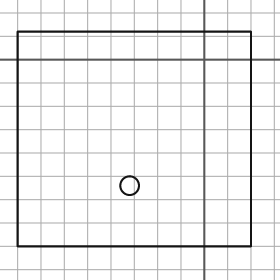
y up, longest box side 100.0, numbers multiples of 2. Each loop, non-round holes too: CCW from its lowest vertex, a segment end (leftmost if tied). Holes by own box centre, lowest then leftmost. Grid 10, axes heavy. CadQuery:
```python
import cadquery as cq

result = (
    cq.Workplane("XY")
    .moveTo(-80.0, -80.0)
    .lineTo(20.0, -80.0)
    .lineTo(20.0, 12.0)
    .lineTo(-80.0, 12.0)
    .close()
    .moveTo(-32.0, -54.0)
    .circle(4.0)
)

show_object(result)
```